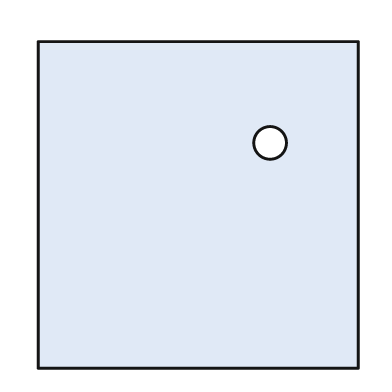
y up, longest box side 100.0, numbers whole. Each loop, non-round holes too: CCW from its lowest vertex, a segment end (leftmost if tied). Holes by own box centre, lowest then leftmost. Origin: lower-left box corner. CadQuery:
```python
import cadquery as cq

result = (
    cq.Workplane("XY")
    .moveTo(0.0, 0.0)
    .lineTo(98.0, 0.0)
    .lineTo(98.0, 100.0)
    .lineTo(0.0, 100.0)
    .close()
    .moveTo(71.0, 69.0)
    .circle(5.0)
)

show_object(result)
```